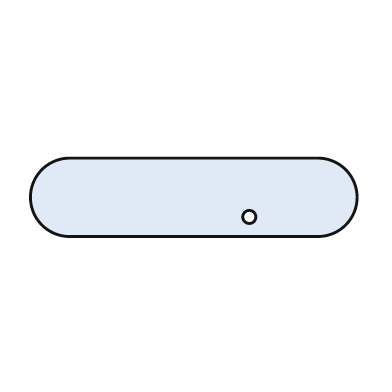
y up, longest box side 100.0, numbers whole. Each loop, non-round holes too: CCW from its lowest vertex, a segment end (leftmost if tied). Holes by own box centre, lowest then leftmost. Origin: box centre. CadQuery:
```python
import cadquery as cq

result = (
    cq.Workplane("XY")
    .moveTo(-38.0, -12.0)
    .lineTo(38.0, -12.0)
    .threePointArc((50.0, 0.0), (38.0, 12.0))
    .lineTo(-38.0, 12.0)
    .threePointArc((-50.0, 0.0), (-38.0, -12.0))
    .close()
    .moveTo(17.0, -6.0)
    .circle(2.0)
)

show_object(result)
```